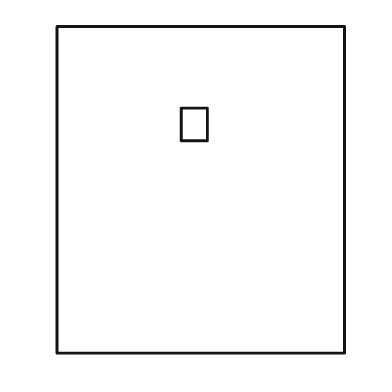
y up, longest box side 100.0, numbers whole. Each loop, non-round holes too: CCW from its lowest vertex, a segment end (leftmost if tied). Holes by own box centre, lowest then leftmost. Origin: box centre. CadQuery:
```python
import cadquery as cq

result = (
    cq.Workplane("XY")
    .moveTo(-44.0, -50.0)
    .lineTo(44.0, -50.0)
    .lineTo(44.0, 50.0)
    .lineTo(-44.0, 50.0)
    .close()
    .moveTo(-6.0, 15.0)
    .lineTo(2.0, 15.0)
    .lineTo(2.0, 25.0)
    .lineTo(-6.0, 25.0)
    .close()
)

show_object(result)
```